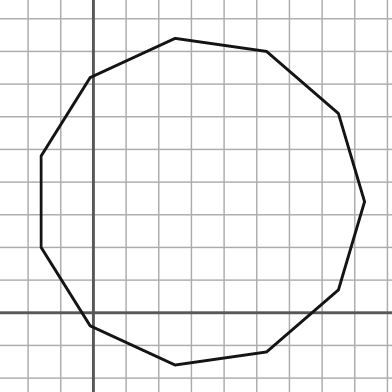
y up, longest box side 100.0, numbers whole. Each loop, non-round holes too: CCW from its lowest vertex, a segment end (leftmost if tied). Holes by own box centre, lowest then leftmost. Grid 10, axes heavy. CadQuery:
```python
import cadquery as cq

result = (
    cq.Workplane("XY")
    .moveTo(25.0, -16.0)
    .lineTo(53.0, -12.0)
    .lineTo(75.0, 7.0)
    .lineTo(83.0, 34.0)
    .lineTo(75.0, 61.0)
    .lineTo(53.0, 80.0)
    .lineTo(25.0, 84.0)
    .lineTo(-1.0, 72.0)
    .lineTo(-16.0, 48.0)
    .lineTo(-16.0, 20.0)
    .lineTo(-1.0, -4.0)
    .close()
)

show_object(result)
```